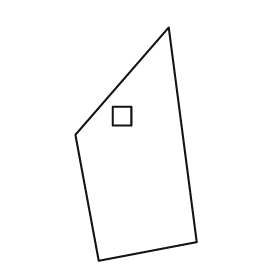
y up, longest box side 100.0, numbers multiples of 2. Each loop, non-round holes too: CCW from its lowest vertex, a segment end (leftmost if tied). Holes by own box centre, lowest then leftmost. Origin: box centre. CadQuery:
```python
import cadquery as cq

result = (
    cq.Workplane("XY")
    .moveTo(-16.0, -50.0)
    .lineTo(26.0, -42.0)
    .lineTo(14.0, 50.0)
    .lineTo(-26.0, 4.0)
    .close()
    .moveTo(-10.0, 8.0)
    .lineTo(-2.0, 8.0)
    .lineTo(-2.0, 16.0)
    .lineTo(-10.0, 16.0)
    .close()
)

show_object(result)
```